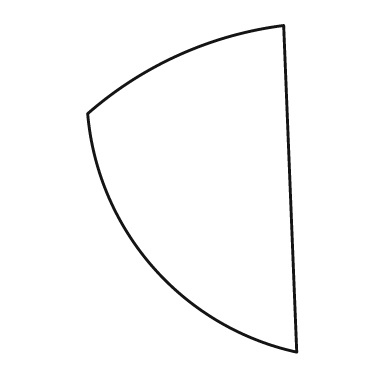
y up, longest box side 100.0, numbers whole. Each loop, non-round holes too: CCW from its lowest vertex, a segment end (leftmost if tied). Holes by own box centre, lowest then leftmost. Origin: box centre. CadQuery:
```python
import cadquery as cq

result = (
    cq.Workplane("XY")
    .moveTo(32.0, -50.0)
    .lineTo(28.0, 50.0)
    .threePointArc((-4.0, 41.0), (-32.0, 23.0))
    .threePointArc((-12.0, -24.0), (32.0, -50.0))
    .close()
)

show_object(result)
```